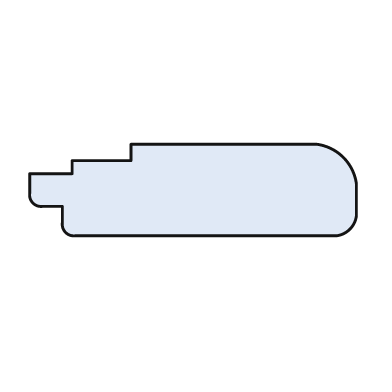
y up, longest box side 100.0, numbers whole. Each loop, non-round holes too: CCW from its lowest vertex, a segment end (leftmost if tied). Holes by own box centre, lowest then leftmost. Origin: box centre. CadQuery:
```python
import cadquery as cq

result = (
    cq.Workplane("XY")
    .moveTo(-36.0, -14.0)
    .lineTo(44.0, -14.0)
    .threePointArc((48.0, -12.0), (50.0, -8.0))
    .lineTo(50.0, 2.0)
    .threePointArc((46.0, 10.0), (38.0, 14.0))
    .lineTo(-19.0, 14.0)
    .lineTo(-19.0, 9.0)
    .lineTo(-37.0, 9.0)
    .lineTo(-37.0, 5.0)
    .lineTo(-50.0, 5.0)
    .lineTo(-50.0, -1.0)
    .threePointArc((-49.0, -4.0), (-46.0, -5.0))
    .lineTo(-40.0, -5.0)
    .lineTo(-40.0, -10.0)
    .threePointArc((-39.0, -13.0), (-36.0, -14.0))
    .close()
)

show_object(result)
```